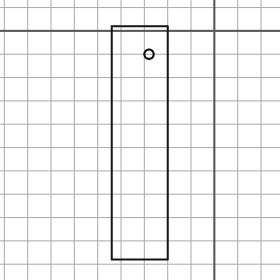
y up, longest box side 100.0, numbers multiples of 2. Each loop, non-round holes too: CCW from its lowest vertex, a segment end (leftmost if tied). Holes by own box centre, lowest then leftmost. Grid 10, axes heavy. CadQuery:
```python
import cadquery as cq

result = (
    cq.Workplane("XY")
    .moveTo(-44.0, -98.0)
    .lineTo(-20.0, -98.0)
    .lineTo(-20.0, 2.0)
    .lineTo(-44.0, 2.0)
    .close()
    .moveTo(-28.0, -10.0)
    .circle(2.0)
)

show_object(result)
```